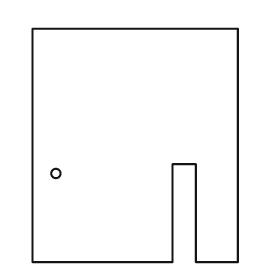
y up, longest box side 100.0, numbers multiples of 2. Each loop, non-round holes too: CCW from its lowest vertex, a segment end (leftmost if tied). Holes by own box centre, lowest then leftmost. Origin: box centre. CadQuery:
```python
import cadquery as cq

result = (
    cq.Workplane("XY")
    .moveTo(-44.0, -50.0)
    .lineTo(16.0, -50.0)
    .lineTo(16.0, -8.0)
    .lineTo(26.0, -8.0)
    .lineTo(26.0, -50.0)
    .lineTo(44.0, -50.0)
    .lineTo(44.0, 50.0)
    .lineTo(-44.0, 50.0)
    .close()
    .moveTo(-34.0, -12.0)
    .circle(2.0)
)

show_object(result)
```